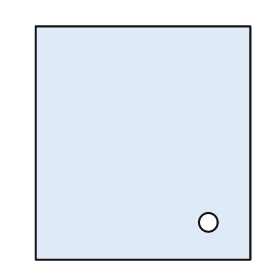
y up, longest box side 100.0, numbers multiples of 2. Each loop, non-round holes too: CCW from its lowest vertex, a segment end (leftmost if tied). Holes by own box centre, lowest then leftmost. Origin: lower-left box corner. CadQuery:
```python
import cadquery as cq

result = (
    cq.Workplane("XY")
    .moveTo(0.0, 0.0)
    .lineTo(92.0, 0.0)
    .lineTo(92.0, 100.0)
    .lineTo(0.0, 100.0)
    .close()
    .moveTo(74.0, 16.0)
    .circle(4.0)
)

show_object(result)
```